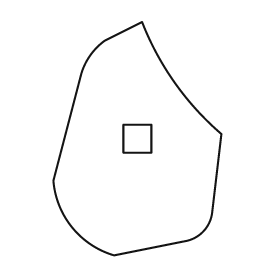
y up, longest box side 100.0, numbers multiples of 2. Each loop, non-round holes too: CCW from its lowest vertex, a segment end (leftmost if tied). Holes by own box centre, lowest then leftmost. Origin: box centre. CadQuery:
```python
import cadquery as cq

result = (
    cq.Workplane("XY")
    .moveTo(-10.0, -50.0)
    .lineTo(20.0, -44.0)
    .threePointArc((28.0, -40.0), (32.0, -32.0))
    .lineTo(36.0, 2.0)
    .threePointArc((16.0, 24.0), (2.0, 50.0))
    .lineTo(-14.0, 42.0)
    .threePointArc((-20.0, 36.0), (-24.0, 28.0))
    .lineTo(-36.0, -18.0)
    .threePointArc((-28.0, -38.0), (-10.0, -50.0))
    .close()
    .moveTo(-6.0, -6.0)
    .lineTo(6.0, -6.0)
    .lineTo(6.0, 6.0)
    .lineTo(-6.0, 6.0)
    .close()
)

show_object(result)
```